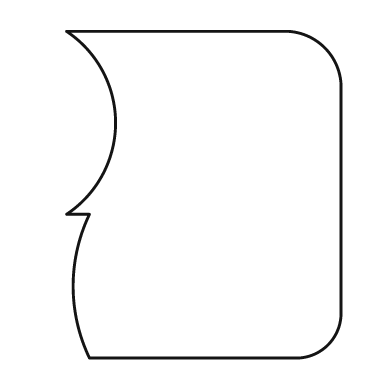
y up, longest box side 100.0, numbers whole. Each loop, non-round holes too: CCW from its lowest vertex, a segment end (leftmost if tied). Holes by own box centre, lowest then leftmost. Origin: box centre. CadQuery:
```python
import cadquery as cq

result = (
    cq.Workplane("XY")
    .moveTo(-35.0, -50.0)
    .lineTo(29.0, -50.0)
    .threePointArc((38.0, -46.0), (42.0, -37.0))
    .lineTo(42.0, 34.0)
    .threePointArc((37.0, 45.0), (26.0, 50.0))
    .lineTo(-42.0, 50.0)
    .threePointArc((-27.0, 22.0), (-42.0, -6.0))
    .lineTo(-35.0, -6.0)
    .threePointArc((-40.0, -28.0), (-35.0, -50.0))
    .close()
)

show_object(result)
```